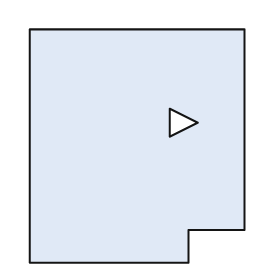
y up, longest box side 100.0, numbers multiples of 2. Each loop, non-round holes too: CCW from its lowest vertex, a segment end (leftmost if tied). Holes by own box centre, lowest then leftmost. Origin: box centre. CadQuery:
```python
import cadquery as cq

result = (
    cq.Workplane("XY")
    .moveTo(-46.0, -50.0)
    .lineTo(22.0, -50.0)
    .lineTo(22.0, -36.0)
    .lineTo(46.0, -36.0)
    .lineTo(46.0, 50.0)
    .lineTo(-46.0, 50.0)
    .close()
    .moveTo(14.0, 4.0)
    .lineTo(26.0, 10.0)
    .lineTo(14.0, 16.0)
    .close()
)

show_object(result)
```